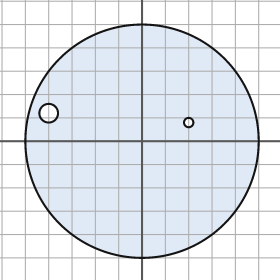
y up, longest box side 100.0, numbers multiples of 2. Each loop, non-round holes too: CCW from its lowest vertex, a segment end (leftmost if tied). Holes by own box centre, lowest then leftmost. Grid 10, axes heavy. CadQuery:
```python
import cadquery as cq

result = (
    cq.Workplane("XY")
    .moveTo(0.0, 0.0)
    .circle(50.0)
    .moveTo(20.0, 8.0)
    .circle(2.0)
    .moveTo(-40.0, 12.0)
    .circle(4.0)
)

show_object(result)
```